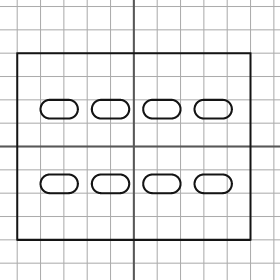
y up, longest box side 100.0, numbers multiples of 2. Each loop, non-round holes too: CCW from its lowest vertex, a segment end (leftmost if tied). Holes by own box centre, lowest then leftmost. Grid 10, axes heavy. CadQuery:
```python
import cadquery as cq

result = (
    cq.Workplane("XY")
    .moveTo(-50.0, -40.0)
    .lineTo(50.0, -40.0)
    .lineTo(50.0, 40.0)
    .lineTo(-50.0, 40.0)
    .close()
    .moveTo(-36.0, -20.0)
    .lineTo(-28.0, -20.0)
    .threePointArc((-24.0, -16.0), (-28.0, -12.0))
    .lineTo(-36.0, -12.0)
    .threePointArc((-40.0, -16.0), (-36.0, -20.0))
    .close()
    .moveTo(-14.0, -20.0)
    .lineTo(-6.0, -20.0)
    .threePointArc((-2.0, -16.0), (-6.0, -12.0))
    .lineTo(-14.0, -12.0)
    .threePointArc((-18.0, -16.0), (-14.0, -20.0))
    .close()
    .moveTo(8.0, -20.0)
    .lineTo(16.0, -20.0)
    .threePointArc((20.0, -16.0), (16.0, -12.0))
    .lineTo(8.0, -12.0)
    .threePointArc((4.0, -16.0), (8.0, -20.0))
    .close()
    .moveTo(30.0, -20.0)
    .lineTo(38.0, -20.0)
    .threePointArc((42.0, -16.0), (38.0, -12.0))
    .lineTo(30.0, -12.0)
    .threePointArc((26.0, -16.0), (30.0, -20.0))
    .close()
    .moveTo(-36.0, 12.0)
    .lineTo(-28.0, 12.0)
    .threePointArc((-24.0, 16.0), (-28.0, 20.0))
    .lineTo(-36.0, 20.0)
    .threePointArc((-40.0, 16.0), (-36.0, 12.0))
    .close()
    .moveTo(-14.0, 12.0)
    .lineTo(-6.0, 12.0)
    .threePointArc((-2.0, 16.0), (-6.0, 20.0))
    .lineTo(-14.0, 20.0)
    .threePointArc((-18.0, 16.0), (-14.0, 12.0))
    .close()
    .moveTo(8.0, 12.0)
    .lineTo(16.0, 12.0)
    .threePointArc((20.0, 16.0), (16.0, 20.0))
    .lineTo(8.0, 20.0)
    .threePointArc((4.0, 16.0), (8.0, 12.0))
    .close()
    .moveTo(30.0, 12.0)
    .lineTo(38.0, 12.0)
    .threePointArc((42.0, 16.0), (38.0, 20.0))
    .lineTo(30.0, 20.0)
    .threePointArc((26.0, 16.0), (30.0, 12.0))
    .close()
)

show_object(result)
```